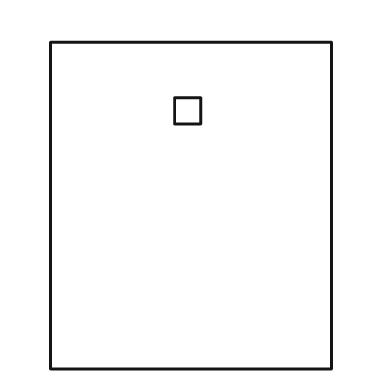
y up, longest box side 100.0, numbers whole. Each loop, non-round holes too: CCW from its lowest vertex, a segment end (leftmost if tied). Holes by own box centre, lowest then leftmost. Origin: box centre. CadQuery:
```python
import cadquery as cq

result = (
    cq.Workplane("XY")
    .moveTo(-43.0, -50.0)
    .lineTo(43.0, -50.0)
    .lineTo(43.0, 50.0)
    .lineTo(-43.0, 50.0)
    .close()
    .moveTo(-5.0, 25.0)
    .lineTo(3.0, 25.0)
    .lineTo(3.0, 33.0)
    .lineTo(-5.0, 33.0)
    .close()
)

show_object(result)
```